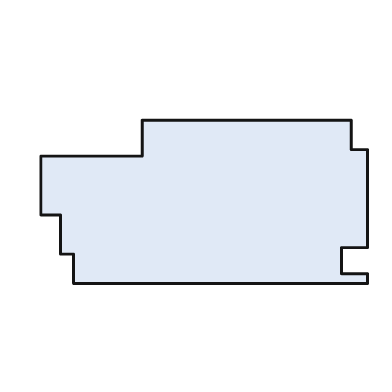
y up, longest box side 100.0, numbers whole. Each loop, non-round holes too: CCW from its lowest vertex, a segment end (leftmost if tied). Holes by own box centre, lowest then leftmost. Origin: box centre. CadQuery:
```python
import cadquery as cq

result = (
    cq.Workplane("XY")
    .moveTo(-40.0, -25.0)
    .lineTo(50.0, -25.0)
    .lineTo(50.0, -22.0)
    .lineTo(42.0, -22.0)
    .lineTo(42.0, -14.0)
    .lineTo(50.0, -14.0)
    .lineTo(50.0, 16.0)
    .lineTo(45.0, 16.0)
    .lineTo(45.0, 25.0)
    .lineTo(-19.0, 25.0)
    .lineTo(-19.0, 14.0)
    .lineTo(-50.0, 14.0)
    .lineTo(-50.0, -4.0)
    .lineTo(-44.0, -4.0)
    .lineTo(-44.0, -16.0)
    .lineTo(-40.0, -16.0)
    .close()
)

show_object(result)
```